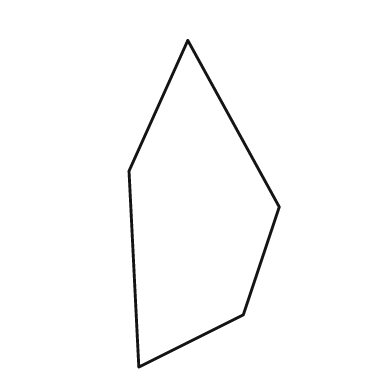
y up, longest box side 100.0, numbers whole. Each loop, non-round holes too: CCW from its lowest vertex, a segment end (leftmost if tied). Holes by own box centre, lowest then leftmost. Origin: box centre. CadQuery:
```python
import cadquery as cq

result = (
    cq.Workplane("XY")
    .moveTo(-20.0, -50.0)
    .lineTo(12.0, -34.0)
    .lineTo(23.0, -1.0)
    .lineTo(-5.0, 50.0)
    .lineTo(-23.0, 10.0)
    .close()
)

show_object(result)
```